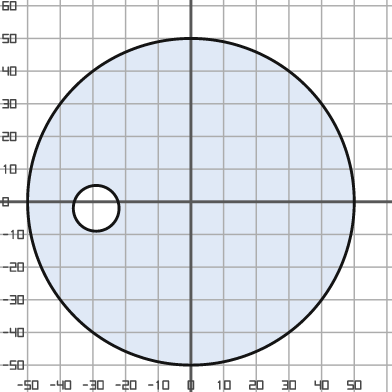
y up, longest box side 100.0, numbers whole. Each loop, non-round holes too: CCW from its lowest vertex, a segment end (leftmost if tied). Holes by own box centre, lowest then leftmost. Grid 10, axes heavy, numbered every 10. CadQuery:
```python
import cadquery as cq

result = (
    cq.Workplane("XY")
    .moveTo(0.0, 0.0)
    .circle(50.0)
    .moveTo(-29.0, -2.0)
    .circle(7.0)
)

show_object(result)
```